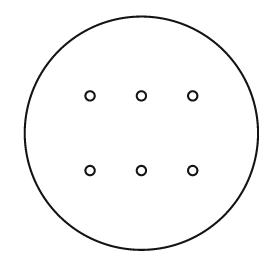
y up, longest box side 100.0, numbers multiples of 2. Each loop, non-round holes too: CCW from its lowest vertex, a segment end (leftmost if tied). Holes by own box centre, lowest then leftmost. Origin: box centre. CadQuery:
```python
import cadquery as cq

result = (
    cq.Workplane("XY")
    .moveTo(0.0, 0.0)
    .circle(50.0)
    .moveTo(-22.0, -16.0)
    .circle(2.0)
    .moveTo(0.0, -16.0)
    .circle(2.0)
    .moveTo(22.0, -16.0)
    .circle(2.0)
    .moveTo(-22.0, 16.0)
    .circle(2.0)
    .moveTo(0.0, 16.0)
    .circle(2.0)
    .moveTo(22.0, 16.0)
    .circle(2.0)
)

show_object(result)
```